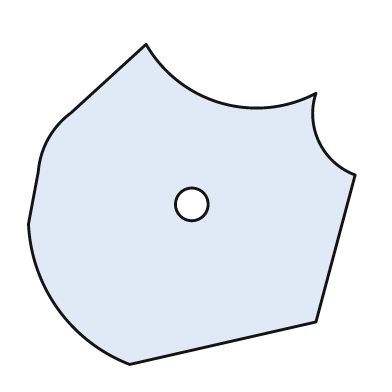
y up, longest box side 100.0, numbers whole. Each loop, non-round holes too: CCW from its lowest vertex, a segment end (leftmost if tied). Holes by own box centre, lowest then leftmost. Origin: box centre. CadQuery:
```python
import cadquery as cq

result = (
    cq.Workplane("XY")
    .moveTo(-19.0, -49.0)
    .lineTo(38.0, -36.0)
    .lineTo(50.0, 9.0)
    .threePointArc((39.0, 19.0), (38.0, 34.0))
    .threePointArc((9.0, 31.0), (-14.0, 49.0))
    .lineTo(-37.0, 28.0)
    .threePointArc((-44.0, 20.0), (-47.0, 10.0))
    .lineTo(-50.0, -6.0)
    .threePointArc((-41.0, -32.0), (-19.0, -49.0))
    .close()
    .moveTo(0.0, 0.0)
    .circle(5.0)
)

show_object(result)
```